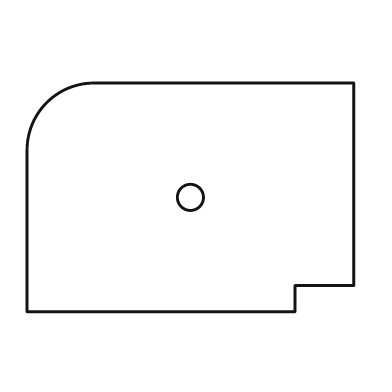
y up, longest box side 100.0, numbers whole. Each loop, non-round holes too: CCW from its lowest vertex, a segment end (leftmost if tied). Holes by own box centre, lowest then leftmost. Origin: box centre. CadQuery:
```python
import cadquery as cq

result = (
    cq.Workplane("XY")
    .moveTo(-50.0, -35.0)
    .lineTo(32.0, -35.0)
    .lineTo(32.0, -27.0)
    .lineTo(50.0, -27.0)
    .lineTo(50.0, 35.0)
    .lineTo(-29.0, 35.0)
    .threePointArc((-44.0, 29.0), (-50.0, 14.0))
    .close()
    .moveTo(0.0, 0.0)
    .circle(4.0)
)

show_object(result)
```